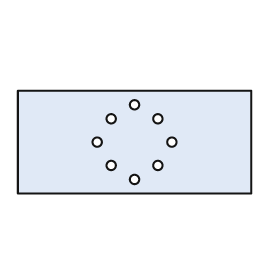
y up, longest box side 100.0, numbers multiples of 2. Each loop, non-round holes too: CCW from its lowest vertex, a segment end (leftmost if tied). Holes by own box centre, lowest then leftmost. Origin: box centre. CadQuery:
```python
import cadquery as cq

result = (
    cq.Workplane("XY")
    .moveTo(-50.0, -22.0)
    .lineTo(50.0, -22.0)
    .lineTo(50.0, 22.0)
    .lineTo(-50.0, 22.0)
    .close()
    .moveTo(0.0, -16.0)
    .circle(2.0)
    .moveTo(-10.0, -10.0)
    .circle(2.0)
    .moveTo(10.0, -10.0)
    .circle(2.0)
    .moveTo(-16.0, 0.0)
    .circle(2.0)
    .moveTo(16.0, 0.0)
    .circle(2.0)
    .moveTo(-10.0, 10.0)
    .circle(2.0)
    .moveTo(10.0, 10.0)
    .circle(2.0)
    .moveTo(0.0, 16.0)
    .circle(2.0)
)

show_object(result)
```